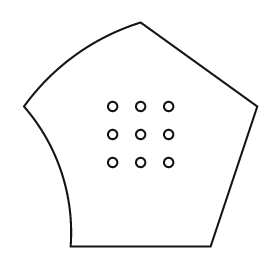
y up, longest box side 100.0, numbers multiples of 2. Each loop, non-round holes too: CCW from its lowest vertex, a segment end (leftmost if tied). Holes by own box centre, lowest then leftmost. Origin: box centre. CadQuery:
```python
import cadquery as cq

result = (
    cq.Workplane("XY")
    .moveTo(-30.0, -48.0)
    .lineTo(30.0, -48.0)
    .lineTo(50.0, 12.0)
    .lineTo(0.0, 48.0)
    .threePointArc((-28.0, 34.0), (-50.0, 12.0))
    .threePointArc((-34.0, -16.0), (-30.0, -48.0))
    .close()
    .moveTo(-12.0, -12.0)
    .circle(2.0)
    .moveTo(0.0, -12.0)
    .circle(2.0)
    .moveTo(12.0, -12.0)
    .circle(2.0)
    .moveTo(-12.0, 0.0)
    .circle(2.0)
    .moveTo(0.0, 0.0)
    .circle(2.0)
    .moveTo(12.0, 0.0)
    .circle(2.0)
    .moveTo(-12.0, 12.0)
    .circle(2.0)
    .moveTo(0.0, 12.0)
    .circle(2.0)
    .moveTo(12.0, 12.0)
    .circle(2.0)
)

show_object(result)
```